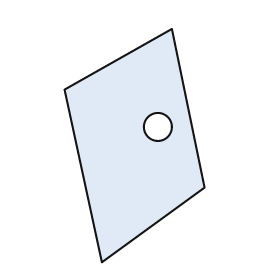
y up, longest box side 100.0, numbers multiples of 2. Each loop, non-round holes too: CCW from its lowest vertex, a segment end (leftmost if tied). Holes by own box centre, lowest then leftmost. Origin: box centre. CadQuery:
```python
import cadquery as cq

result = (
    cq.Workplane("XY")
    .moveTo(-14.0, -50.0)
    .lineTo(30.0, -18.0)
    .lineTo(16.0, 50.0)
    .lineTo(-30.0, 24.0)
    .close()
    .moveTo(10.0, 8.0)
    .circle(6.0)
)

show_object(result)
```